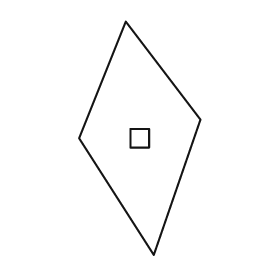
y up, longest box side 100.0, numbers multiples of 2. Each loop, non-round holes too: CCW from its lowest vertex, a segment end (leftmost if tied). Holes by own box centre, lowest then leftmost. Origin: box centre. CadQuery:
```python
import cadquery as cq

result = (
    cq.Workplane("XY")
    .moveTo(6.0, -50.0)
    .lineTo(26.0, 8.0)
    .lineTo(-6.0, 50.0)
    .lineTo(-26.0, 0.0)
    .close()
    .moveTo(-4.0, -4.0)
    .lineTo(4.0, -4.0)
    .lineTo(4.0, 4.0)
    .lineTo(-4.0, 4.0)
    .close()
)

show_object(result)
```